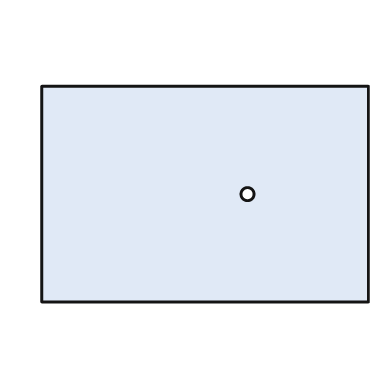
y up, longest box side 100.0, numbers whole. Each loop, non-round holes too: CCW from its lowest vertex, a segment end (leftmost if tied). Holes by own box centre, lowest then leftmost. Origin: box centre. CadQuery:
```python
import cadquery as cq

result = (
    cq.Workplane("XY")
    .moveTo(-50.0, -33.0)
    .lineTo(50.0, -33.0)
    .lineTo(50.0, 33.0)
    .lineTo(-50.0, 33.0)
    .close()
    .moveTo(13.0, 0.0)
    .circle(2.0)
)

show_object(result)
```